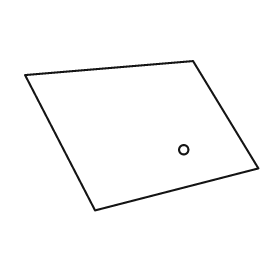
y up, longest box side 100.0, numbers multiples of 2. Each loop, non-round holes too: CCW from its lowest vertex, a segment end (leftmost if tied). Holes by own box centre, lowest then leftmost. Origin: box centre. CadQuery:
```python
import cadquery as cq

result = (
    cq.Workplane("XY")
    .moveTo(-20.0, -32.0)
    .lineTo(50.0, -14.0)
    .lineTo(22.0, 32.0)
    .lineTo(-50.0, 26.0)
    .close()
    .moveTo(18.0, -6.0)
    .circle(2.0)
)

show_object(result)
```